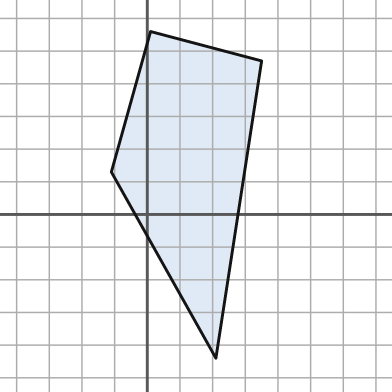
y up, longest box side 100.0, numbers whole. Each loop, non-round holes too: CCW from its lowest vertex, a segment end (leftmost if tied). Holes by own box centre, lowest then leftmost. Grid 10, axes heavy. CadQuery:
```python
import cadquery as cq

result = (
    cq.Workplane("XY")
    .moveTo(21.0, -44.0)
    .lineTo(35.0, 47.0)
    .lineTo(1.0, 56.0)
    .lineTo(-11.0, 13.0)
    .close()
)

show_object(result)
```